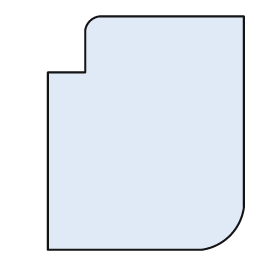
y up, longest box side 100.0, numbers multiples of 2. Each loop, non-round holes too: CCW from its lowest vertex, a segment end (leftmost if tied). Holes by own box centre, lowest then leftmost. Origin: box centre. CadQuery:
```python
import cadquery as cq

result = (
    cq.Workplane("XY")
    .moveTo(-42.0, -50.0)
    .lineTo(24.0, -50.0)
    .threePointArc((36.0, -44.0), (42.0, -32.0))
    .lineTo(42.0, 50.0)
    .lineTo(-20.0, 50.0)
    .threePointArc((-24.0, 48.0), (-26.0, 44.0))
    .lineTo(-26.0, 26.0)
    .lineTo(-42.0, 26.0)
    .close()
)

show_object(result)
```